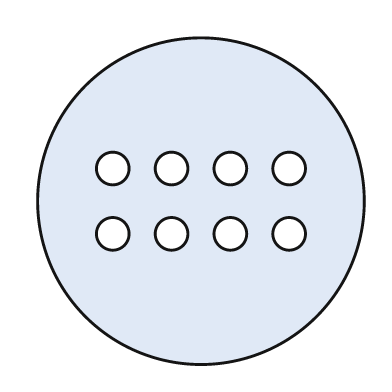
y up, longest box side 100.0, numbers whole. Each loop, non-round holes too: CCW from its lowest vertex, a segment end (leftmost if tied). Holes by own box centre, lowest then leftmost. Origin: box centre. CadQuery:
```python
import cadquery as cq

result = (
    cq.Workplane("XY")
    .moveTo(0.0, 0.0)
    .circle(50.0)
    .moveTo(-27.0, -10.0)
    .circle(5.0)
    .moveTo(-9.0, -10.0)
    .circle(5.0)
    .moveTo(9.0, -10.0)
    .circle(5.0)
    .moveTo(27.0, -10.0)
    .circle(5.0)
    .moveTo(-27.0, 10.0)
    .circle(5.0)
    .moveTo(-9.0, 10.0)
    .circle(5.0)
    .moveTo(9.0, 10.0)
    .circle(5.0)
    .moveTo(27.0, 10.0)
    .circle(5.0)
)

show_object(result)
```